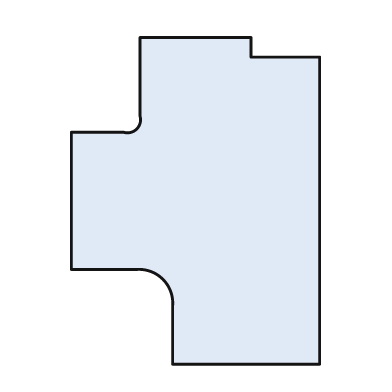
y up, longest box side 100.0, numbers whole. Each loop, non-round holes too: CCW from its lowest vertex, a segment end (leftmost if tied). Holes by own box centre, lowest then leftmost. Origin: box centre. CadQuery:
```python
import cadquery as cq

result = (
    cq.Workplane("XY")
    .moveTo(-7.0, -50.0)
    .lineTo(38.0, -50.0)
    .lineTo(38.0, 44.0)
    .lineTo(17.0, 44.0)
    .lineTo(17.0, 50.0)
    .lineTo(-17.0, 50.0)
    .lineTo(-17.0, 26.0)
    .threePointArc((-18.0, 22.0), (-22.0, 21.0))
    .lineTo(-38.0, 21.0)
    .lineTo(-38.0, -21.0)
    .lineTo(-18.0, -21.0)
    .threePointArc((-10.0, -24.0), (-7.0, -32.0))
    .close()
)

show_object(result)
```